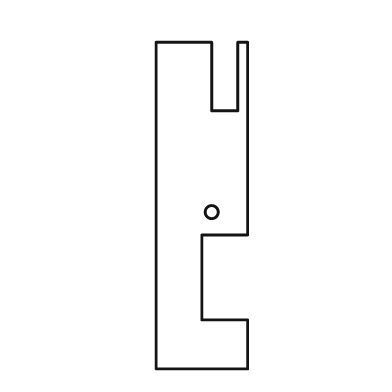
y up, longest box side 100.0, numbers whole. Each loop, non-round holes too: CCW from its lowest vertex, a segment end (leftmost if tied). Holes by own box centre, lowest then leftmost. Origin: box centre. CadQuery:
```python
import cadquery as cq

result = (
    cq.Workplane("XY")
    .moveTo(-14.0, -50.0)
    .lineTo(14.0, -50.0)
    .lineTo(14.0, -35.0)
    .lineTo(0.0, -35.0)
    .lineTo(0.0, -9.0)
    .lineTo(14.0, -9.0)
    .lineTo(14.0, 50.0)
    .lineTo(11.0, 50.0)
    .lineTo(11.0, 29.0)
    .lineTo(3.0, 29.0)
    .lineTo(3.0, 50.0)
    .lineTo(-14.0, 50.0)
    .close()
    .moveTo(3.0, -2.0)
    .circle(2.0)
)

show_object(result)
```